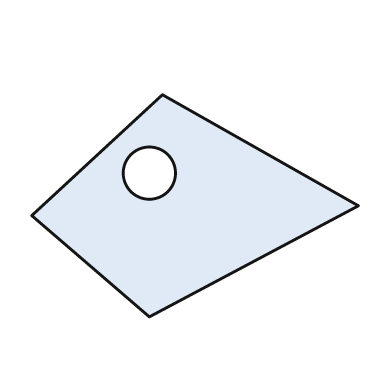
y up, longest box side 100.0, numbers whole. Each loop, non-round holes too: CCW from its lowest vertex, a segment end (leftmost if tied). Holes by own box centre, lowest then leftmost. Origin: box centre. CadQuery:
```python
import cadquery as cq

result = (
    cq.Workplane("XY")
    .moveTo(-14.0, -34.0)
    .lineTo(50.0, 0.0)
    .lineTo(-10.0, 34.0)
    .lineTo(-50.0, -3.0)
    .close()
    .moveTo(-14.0, 10.0)
    .circle(8.0)
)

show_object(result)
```